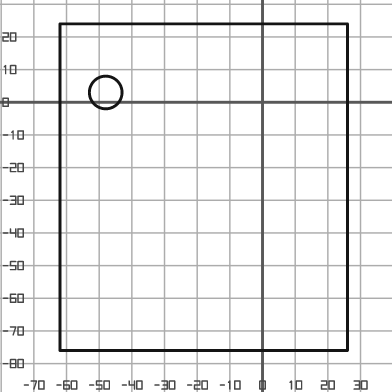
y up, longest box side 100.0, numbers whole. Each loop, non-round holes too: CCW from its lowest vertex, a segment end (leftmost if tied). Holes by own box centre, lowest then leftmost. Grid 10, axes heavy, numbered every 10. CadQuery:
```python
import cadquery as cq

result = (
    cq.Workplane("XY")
    .moveTo(-62.0, -76.0)
    .lineTo(26.0, -76.0)
    .lineTo(26.0, 24.0)
    .lineTo(-62.0, 24.0)
    .close()
    .moveTo(-48.0, 3.0)
    .circle(5.0)
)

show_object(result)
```